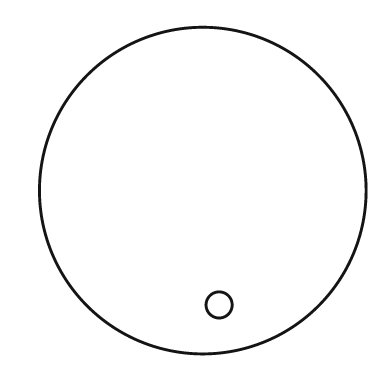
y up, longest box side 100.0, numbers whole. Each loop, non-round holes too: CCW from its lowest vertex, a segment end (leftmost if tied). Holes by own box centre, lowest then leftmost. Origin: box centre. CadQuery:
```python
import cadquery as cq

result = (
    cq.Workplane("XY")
    .moveTo(0.0, 0.0)
    .circle(50.0)
    .moveTo(5.0, -35.0)
    .circle(4.0)
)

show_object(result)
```